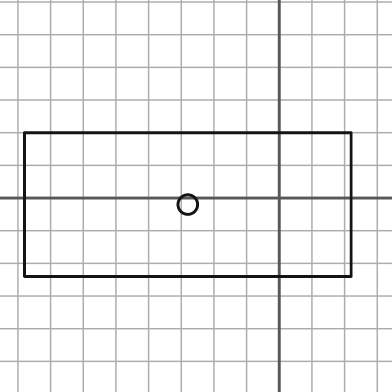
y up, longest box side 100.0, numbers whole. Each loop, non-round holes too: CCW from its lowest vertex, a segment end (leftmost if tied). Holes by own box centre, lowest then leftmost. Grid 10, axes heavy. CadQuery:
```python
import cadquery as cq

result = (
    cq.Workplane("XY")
    .moveTo(-78.0, -24.0)
    .lineTo(22.0, -24.0)
    .lineTo(22.0, 20.0)
    .lineTo(-78.0, 20.0)
    .close()
    .moveTo(-28.0, -2.0)
    .circle(3.0)
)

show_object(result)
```